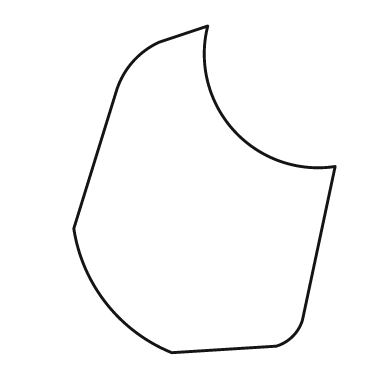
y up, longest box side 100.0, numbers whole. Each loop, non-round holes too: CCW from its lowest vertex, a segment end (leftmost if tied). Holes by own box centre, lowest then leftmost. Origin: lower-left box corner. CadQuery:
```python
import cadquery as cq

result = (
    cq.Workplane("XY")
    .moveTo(30.0, 0.0)
    .lineTo(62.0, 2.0)
    .threePointArc((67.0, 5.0), (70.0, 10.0))
    .lineTo(80.0, 57.0)
    .threePointArc((49.0, 68.0), (41.0, 100.0))
    .lineTo(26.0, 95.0)
    .threePointArc((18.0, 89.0), (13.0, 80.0))
    .lineTo(0.0, 38.0)
    .threePointArc((10.0, 15.0), (30.0, 0.0))
    .close()
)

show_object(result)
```